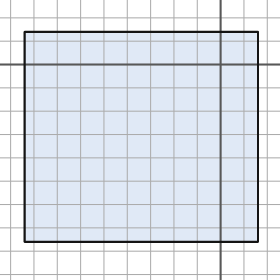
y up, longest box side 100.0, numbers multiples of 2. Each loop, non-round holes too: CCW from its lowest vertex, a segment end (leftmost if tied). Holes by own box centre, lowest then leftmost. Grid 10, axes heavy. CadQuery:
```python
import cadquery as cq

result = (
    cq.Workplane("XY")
    .moveTo(-84.0, -76.0)
    .lineTo(16.0, -76.0)
    .lineTo(16.0, 14.0)
    .lineTo(-84.0, 14.0)
    .close()
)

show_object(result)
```